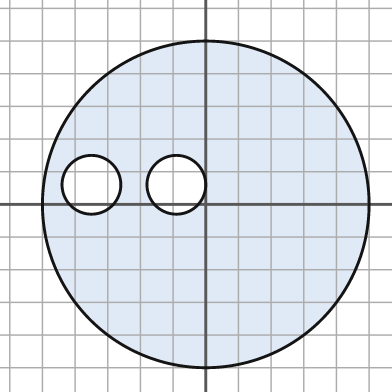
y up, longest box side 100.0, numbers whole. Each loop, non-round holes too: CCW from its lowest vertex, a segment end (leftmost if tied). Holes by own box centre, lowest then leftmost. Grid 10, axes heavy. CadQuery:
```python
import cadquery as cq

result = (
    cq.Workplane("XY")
    .moveTo(0.0, 0.0)
    .circle(50.0)
    .moveTo(-35.0, 6.0)
    .circle(9.0)
    .moveTo(-9.0, 6.0)
    .circle(9.0)
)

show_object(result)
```